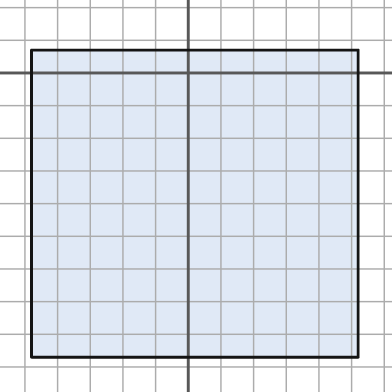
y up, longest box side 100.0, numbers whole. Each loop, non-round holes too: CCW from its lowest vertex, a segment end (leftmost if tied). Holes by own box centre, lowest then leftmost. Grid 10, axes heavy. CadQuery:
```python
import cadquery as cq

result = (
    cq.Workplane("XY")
    .moveTo(-48.0, -87.0)
    .lineTo(52.0, -87.0)
    .lineTo(52.0, 7.0)
    .lineTo(-48.0, 7.0)
    .close()
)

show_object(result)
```